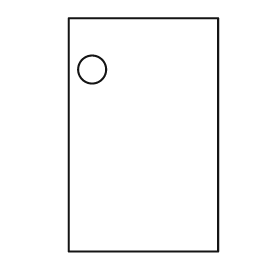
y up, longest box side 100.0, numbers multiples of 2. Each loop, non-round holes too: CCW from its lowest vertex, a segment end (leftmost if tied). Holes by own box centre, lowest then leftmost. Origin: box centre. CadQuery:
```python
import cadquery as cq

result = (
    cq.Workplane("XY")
    .moveTo(-32.0, -50.0)
    .lineTo(32.0, -50.0)
    .lineTo(32.0, 50.0)
    .lineTo(-32.0, 50.0)
    .close()
    .moveTo(-22.0, 28.0)
    .circle(6.0)
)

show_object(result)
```